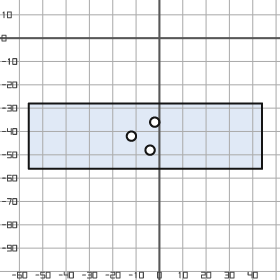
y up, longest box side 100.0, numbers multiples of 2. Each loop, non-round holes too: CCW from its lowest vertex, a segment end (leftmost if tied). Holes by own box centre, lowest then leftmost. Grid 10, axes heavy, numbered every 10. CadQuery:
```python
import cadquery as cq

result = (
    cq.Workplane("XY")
    .moveTo(-56.0, -56.0)
    .lineTo(44.0, -56.0)
    .lineTo(44.0, -28.0)
    .lineTo(-56.0, -28.0)
    .close()
    .moveTo(-4.0, -48.0)
    .circle(2.0)
    .moveTo(-12.0, -42.0)
    .circle(2.0)
    .moveTo(-2.0, -36.0)
    .circle(2.0)
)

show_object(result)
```